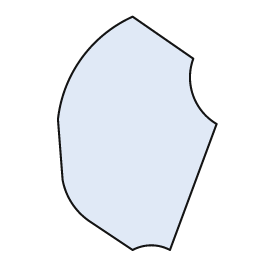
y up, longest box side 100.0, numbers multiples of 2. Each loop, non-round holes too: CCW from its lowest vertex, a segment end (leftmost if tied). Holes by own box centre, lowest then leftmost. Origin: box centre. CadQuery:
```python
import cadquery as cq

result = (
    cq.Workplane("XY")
    .moveTo(-2.0, -50.0)
    .threePointArc((6.0, -48.0), (14.0, -50.0))
    .lineTo(34.0, 4.0)
    .threePointArc((24.0, 16.0), (24.0, 32.0))
    .lineTo(-2.0, 50.0)
    .threePointArc((-24.0, 32.0), (-34.0, 6.0))
    .lineTo(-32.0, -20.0)
    .threePointArc((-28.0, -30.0), (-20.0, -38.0))
    .close()
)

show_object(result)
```